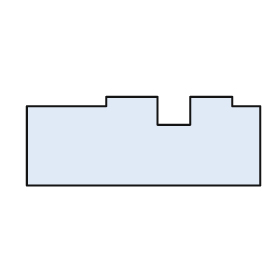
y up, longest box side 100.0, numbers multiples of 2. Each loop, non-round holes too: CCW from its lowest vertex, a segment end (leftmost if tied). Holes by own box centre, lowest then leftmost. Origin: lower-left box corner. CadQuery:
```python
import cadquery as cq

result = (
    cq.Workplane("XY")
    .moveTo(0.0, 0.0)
    .lineTo(100.0, 0.0)
    .lineTo(100.0, 34.0)
    .lineTo(88.0, 34.0)
    .lineTo(88.0, 38.0)
    .lineTo(70.0, 38.0)
    .lineTo(70.0, 26.0)
    .lineTo(56.0, 26.0)
    .lineTo(56.0, 38.0)
    .lineTo(34.0, 38.0)
    .lineTo(34.0, 34.0)
    .lineTo(0.0, 34.0)
    .close()
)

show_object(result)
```